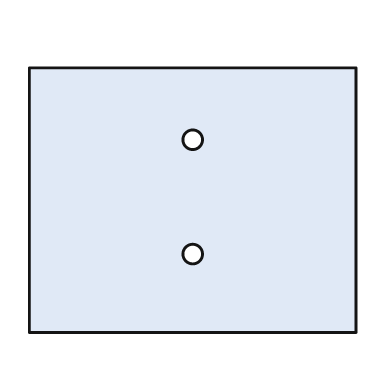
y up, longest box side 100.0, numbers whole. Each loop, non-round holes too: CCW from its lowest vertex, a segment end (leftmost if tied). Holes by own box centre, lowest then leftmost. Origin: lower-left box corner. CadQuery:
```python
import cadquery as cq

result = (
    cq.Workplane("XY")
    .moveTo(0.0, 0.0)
    .lineTo(100.0, 0.0)
    .lineTo(100.0, 81.0)
    .lineTo(0.0, 81.0)
    .close()
    .moveTo(50.0, 24.0)
    .circle(3.0)
    .moveTo(50.0, 59.0)
    .circle(3.0)
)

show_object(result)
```